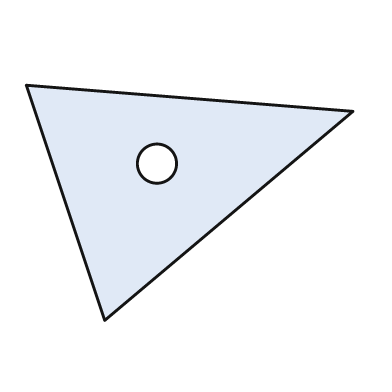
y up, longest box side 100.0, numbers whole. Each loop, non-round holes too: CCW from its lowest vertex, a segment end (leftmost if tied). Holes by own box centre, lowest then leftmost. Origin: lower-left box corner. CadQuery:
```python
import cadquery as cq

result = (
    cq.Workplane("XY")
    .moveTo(24.0, 0.0)
    .lineTo(100.0, 64.0)
    .lineTo(0.0, 72.0)
    .close()
    .moveTo(40.0, 48.0)
    .circle(6.0)
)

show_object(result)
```